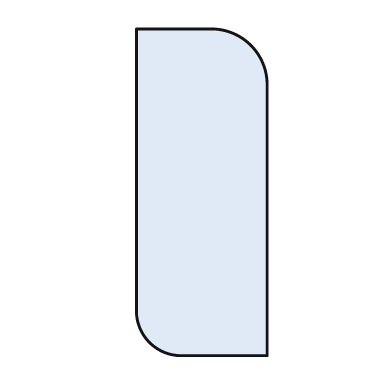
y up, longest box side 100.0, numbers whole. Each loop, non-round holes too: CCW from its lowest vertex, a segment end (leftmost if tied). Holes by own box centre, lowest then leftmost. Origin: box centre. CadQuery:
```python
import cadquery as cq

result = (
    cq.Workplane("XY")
    .moveTo(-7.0, -50.0)
    .lineTo(20.0, -50.0)
    .lineTo(20.0, 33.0)
    .threePointArc((15.0, 45.0), (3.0, 50.0))
    .lineTo(-20.0, 50.0)
    .lineTo(-20.0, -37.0)
    .threePointArc((-16.0, -46.0), (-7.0, -50.0))
    .close()
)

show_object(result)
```